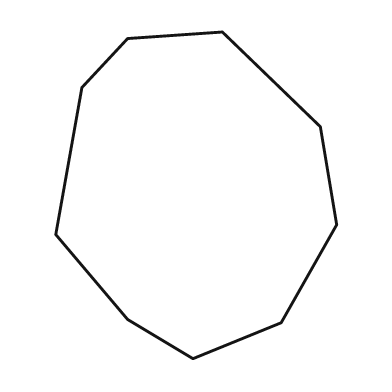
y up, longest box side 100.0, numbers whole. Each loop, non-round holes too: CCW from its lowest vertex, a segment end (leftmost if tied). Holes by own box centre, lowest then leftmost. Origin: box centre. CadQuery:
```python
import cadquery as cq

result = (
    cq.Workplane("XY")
    .moveTo(-1.0, -50.0)
    .lineTo(26.0, -39.0)
    .lineTo(43.0, -9.0)
    .lineTo(38.0, 21.0)
    .lineTo(8.0, 50.0)
    .lineTo(-21.0, 48.0)
    .lineTo(-35.0, 33.0)
    .lineTo(-43.0, -12.0)
    .lineTo(-21.0, -38.0)
    .close()
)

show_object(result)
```